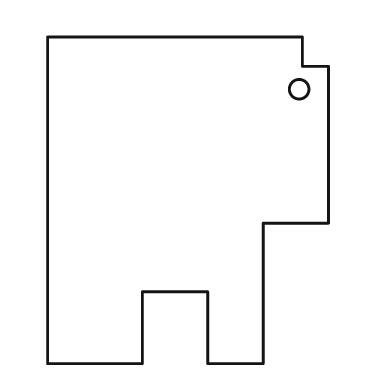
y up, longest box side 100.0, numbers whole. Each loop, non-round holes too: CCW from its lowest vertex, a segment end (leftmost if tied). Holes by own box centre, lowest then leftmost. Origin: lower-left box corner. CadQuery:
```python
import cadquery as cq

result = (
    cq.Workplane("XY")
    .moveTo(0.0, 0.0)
    .lineTo(29.0, 0.0)
    .lineTo(29.0, 22.0)
    .lineTo(49.0, 22.0)
    .lineTo(49.0, 0.0)
    .lineTo(66.0, 0.0)
    .lineTo(66.0, 43.0)
    .lineTo(86.0, 43.0)
    .lineTo(86.0, 91.0)
    .lineTo(78.0, 91.0)
    .lineTo(78.0, 100.0)
    .lineTo(0.0, 100.0)
    .close()
    .moveTo(77.0, 84.0)
    .circle(3.0)
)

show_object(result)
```